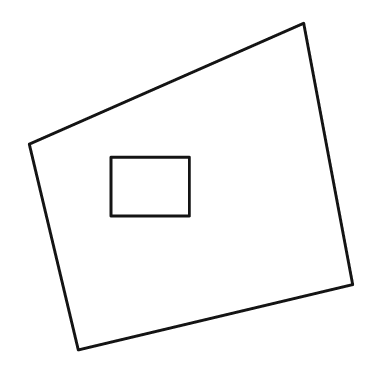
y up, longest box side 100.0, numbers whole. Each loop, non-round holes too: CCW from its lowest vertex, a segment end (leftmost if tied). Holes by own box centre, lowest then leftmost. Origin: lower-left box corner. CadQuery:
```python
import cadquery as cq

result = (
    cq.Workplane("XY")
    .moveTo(15.0, 0.0)
    .lineTo(99.0, 20.0)
    .lineTo(84.0, 100.0)
    .lineTo(0.0, 63.0)
    .close()
    .moveTo(25.0, 41.0)
    .lineTo(49.0, 41.0)
    .lineTo(49.0, 59.0)
    .lineTo(25.0, 59.0)
    .close()
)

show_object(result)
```